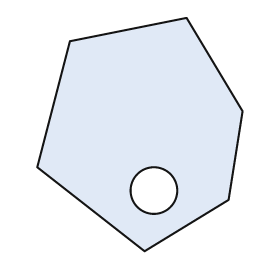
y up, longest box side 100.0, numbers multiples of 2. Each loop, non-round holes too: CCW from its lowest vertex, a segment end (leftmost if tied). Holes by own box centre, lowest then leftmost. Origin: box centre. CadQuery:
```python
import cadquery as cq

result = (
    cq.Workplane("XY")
    .moveTo(2.0, -50.0)
    .lineTo(38.0, -28.0)
    .lineTo(44.0, 10.0)
    .lineTo(20.0, 50.0)
    .lineTo(-30.0, 40.0)
    .lineTo(-44.0, -14.0)
    .close()
    .moveTo(6.0, -24.0)
    .circle(10.0)
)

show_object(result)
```